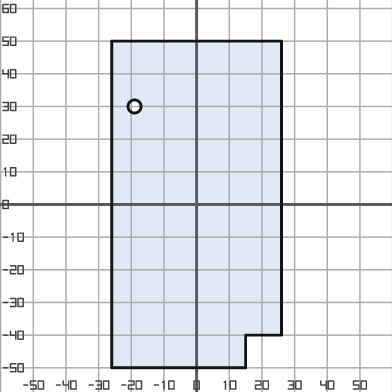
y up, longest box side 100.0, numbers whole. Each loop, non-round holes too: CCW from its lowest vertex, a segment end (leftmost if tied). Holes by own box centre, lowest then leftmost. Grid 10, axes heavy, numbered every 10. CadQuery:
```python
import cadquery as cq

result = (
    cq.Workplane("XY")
    .moveTo(-26.0, -50.0)
    .lineTo(15.0, -50.0)
    .lineTo(15.0, -40.0)
    .lineTo(26.0, -40.0)
    .lineTo(26.0, 50.0)
    .lineTo(-26.0, 50.0)
    .close()
    .moveTo(-19.0, 30.0)
    .circle(2.0)
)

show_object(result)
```